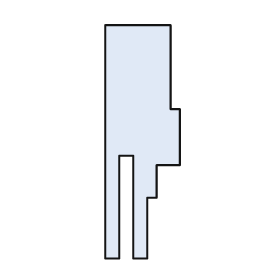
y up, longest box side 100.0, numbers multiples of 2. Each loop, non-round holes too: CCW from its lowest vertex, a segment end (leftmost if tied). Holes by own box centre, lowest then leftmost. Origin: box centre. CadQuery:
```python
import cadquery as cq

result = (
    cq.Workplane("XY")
    .moveTo(-16.0, -50.0)
    .lineTo(-10.0, -50.0)
    .lineTo(-10.0, -6.0)
    .lineTo(-4.0, -6.0)
    .lineTo(-4.0, -50.0)
    .lineTo(2.0, -50.0)
    .lineTo(2.0, -24.0)
    .lineTo(6.0, -24.0)
    .lineTo(6.0, -10.0)
    .lineTo(16.0, -10.0)
    .lineTo(16.0, 14.0)
    .lineTo(12.0, 14.0)
    .lineTo(12.0, 50.0)
    .lineTo(-16.0, 50.0)
    .close()
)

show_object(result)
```